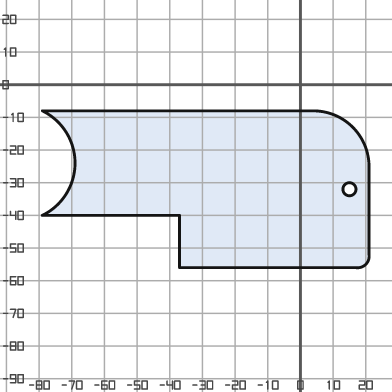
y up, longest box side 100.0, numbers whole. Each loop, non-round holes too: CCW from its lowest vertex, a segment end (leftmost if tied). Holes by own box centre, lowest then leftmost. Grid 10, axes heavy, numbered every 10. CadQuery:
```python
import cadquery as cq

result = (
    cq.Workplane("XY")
    .moveTo(-37.0, -56.0)
    .lineTo(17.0, -56.0)
    .threePointArc((20.0, -55.0), (21.0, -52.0))
    .lineTo(21.0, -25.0)
    .threePointArc((16.0, -13.0), (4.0, -8.0))
    .lineTo(-79.0, -8.0)
    .threePointArc((-69.0, -24.0), (-79.0, -40.0))
    .lineTo(-37.0, -40.0)
    .close()
    .moveTo(15.0, -32.0)
    .circle(2.0)
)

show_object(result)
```